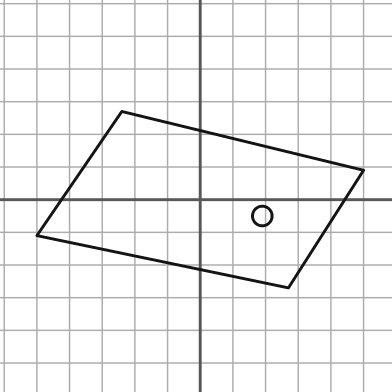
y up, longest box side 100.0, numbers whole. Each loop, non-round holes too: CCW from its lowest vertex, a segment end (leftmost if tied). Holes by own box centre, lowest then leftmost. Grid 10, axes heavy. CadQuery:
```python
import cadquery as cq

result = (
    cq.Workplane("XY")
    .moveTo(27.0, -27.0)
    .lineTo(50.0, 9.0)
    .lineTo(-24.0, 27.0)
    .lineTo(-50.0, -11.0)
    .close()
    .moveTo(19.0, -5.0)
    .circle(3.0)
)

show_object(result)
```